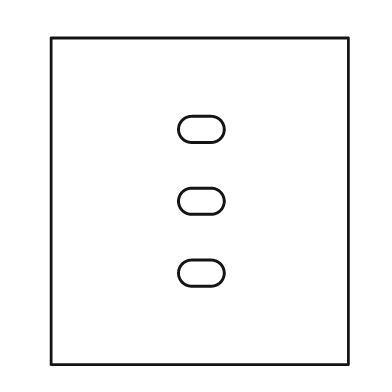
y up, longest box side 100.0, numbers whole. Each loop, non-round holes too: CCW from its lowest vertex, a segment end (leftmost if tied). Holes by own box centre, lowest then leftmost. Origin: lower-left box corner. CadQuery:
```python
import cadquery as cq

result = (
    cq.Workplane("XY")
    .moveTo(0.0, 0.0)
    .lineTo(91.0, 0.0)
    .lineTo(91.0, 100.0)
    .lineTo(0.0, 100.0)
    .close()
    .moveTo(43.0, 24.0)
    .lineTo(49.0, 24.0)
    .threePointArc((53.0, 28.0), (49.0, 32.0))
    .lineTo(43.0, 32.0)
    .threePointArc((39.0, 28.0), (43.0, 24.0))
    .close()
    .moveTo(43.0, 46.0)
    .lineTo(49.0, 46.0)
    .threePointArc((53.0, 50.0), (49.0, 54.0))
    .lineTo(43.0, 54.0)
    .threePointArc((39.0, 50.0), (43.0, 46.0))
    .close()
    .moveTo(43.0, 68.0)
    .lineTo(49.0, 68.0)
    .threePointArc((53.0, 72.0), (49.0, 76.0))
    .lineTo(43.0, 76.0)
    .threePointArc((39.0, 72.0), (43.0, 68.0))
    .close()
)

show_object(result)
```